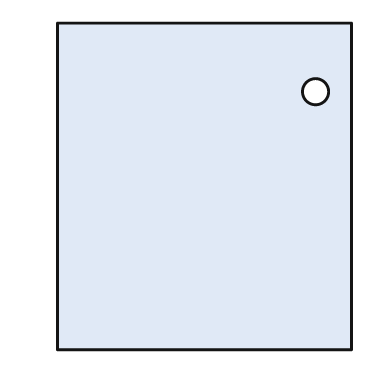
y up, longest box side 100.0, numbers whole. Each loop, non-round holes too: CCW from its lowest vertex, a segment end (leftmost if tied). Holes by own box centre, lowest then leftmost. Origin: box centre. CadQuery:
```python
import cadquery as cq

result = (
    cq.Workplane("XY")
    .moveTo(-45.0, -50.0)
    .lineTo(45.0, -50.0)
    .lineTo(45.0, 50.0)
    .lineTo(-45.0, 50.0)
    .close()
    .moveTo(34.0, 29.0)
    .circle(4.0)
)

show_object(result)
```